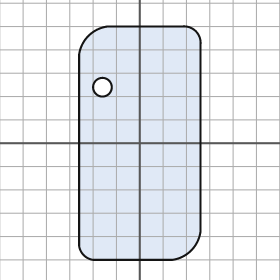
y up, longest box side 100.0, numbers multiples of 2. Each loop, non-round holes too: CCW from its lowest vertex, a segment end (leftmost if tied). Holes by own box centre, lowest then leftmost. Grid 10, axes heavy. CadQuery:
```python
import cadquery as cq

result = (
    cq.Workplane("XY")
    .moveTo(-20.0, -50.0)
    .lineTo(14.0, -50.0)
    .threePointArc((22.0, -46.0), (26.0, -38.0))
    .lineTo(26.0, 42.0)
    .threePointArc((24.0, 48.0), (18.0, 50.0))
    .lineTo(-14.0, 50.0)
    .threePointArc((-22.0, 46.0), (-26.0, 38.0))
    .lineTo(-26.0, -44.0)
    .threePointArc((-24.0, -48.0), (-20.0, -50.0))
    .close()
    .moveTo(-16.0, 24.0)
    .circle(4.0)
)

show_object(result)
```